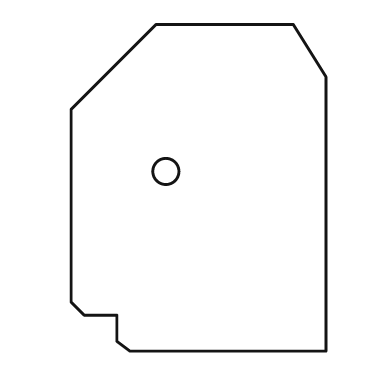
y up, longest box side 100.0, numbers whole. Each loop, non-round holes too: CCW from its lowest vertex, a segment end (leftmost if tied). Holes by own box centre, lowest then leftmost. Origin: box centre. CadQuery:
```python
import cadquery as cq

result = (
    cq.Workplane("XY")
    .moveTo(-21.0, -50.0)
    .lineTo(39.0, -50.0)
    .lineTo(39.0, 34.0)
    .lineTo(29.0, 50.0)
    .lineTo(-13.0, 50.0)
    .lineTo(-39.0, 24.0)
    .lineTo(-39.0, -35.0)
    .lineTo(-35.0, -39.0)
    .lineTo(-25.0, -39.0)
    .lineTo(-25.0, -47.0)
    .close()
    .moveTo(-10.0, 5.0)
    .circle(4.0)
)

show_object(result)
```